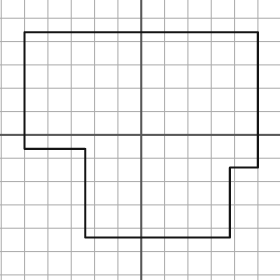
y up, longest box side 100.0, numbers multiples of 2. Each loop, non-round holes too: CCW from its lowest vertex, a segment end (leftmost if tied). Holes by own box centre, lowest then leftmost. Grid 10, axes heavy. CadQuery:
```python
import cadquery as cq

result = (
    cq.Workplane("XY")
    .moveTo(-24.0, -44.0)
    .lineTo(38.0, -44.0)
    .lineTo(38.0, -14.0)
    .lineTo(50.0, -14.0)
    .lineTo(50.0, 44.0)
    .lineTo(-50.0, 44.0)
    .lineTo(-50.0, -6.0)
    .lineTo(-24.0, -6.0)
    .close()
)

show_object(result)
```